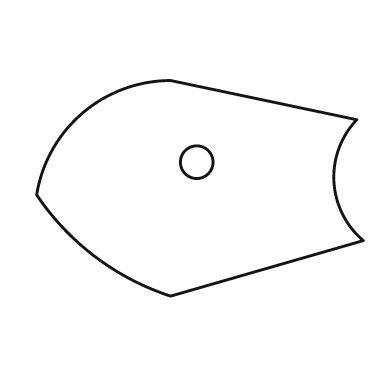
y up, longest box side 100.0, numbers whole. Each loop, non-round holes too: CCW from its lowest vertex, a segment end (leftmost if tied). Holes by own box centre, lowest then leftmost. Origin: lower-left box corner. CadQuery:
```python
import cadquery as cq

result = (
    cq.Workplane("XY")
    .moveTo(41.0, 0.0)
    .lineTo(100.0, 17.0)
    .threePointArc((91.0, 35.0), (98.0, 54.0))
    .lineTo(41.0, 66.0)
    .threePointArc((14.0, 56.0), (0.0, 31.0))
    .threePointArc((18.0, 12.0), (41.0, 0.0))
    .close()
    .moveTo(49.0, 41.0)
    .circle(5.0)
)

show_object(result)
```